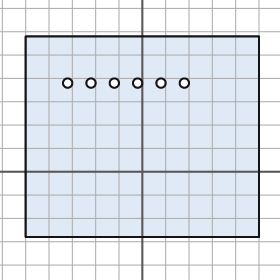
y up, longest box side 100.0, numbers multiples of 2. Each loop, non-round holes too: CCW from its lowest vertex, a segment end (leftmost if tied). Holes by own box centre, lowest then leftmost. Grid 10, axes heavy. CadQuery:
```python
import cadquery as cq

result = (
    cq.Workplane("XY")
    .moveTo(-50.0, -28.0)
    .lineTo(50.0, -28.0)
    .lineTo(50.0, 58.0)
    .lineTo(-50.0, 58.0)
    .close()
    .moveTo(-32.0, 38.0)
    .circle(2.0)
    .moveTo(-22.0, 38.0)
    .circle(2.0)
    .moveTo(-12.0, 38.0)
    .circle(2.0)
    .moveTo(-2.0, 38.0)
    .circle(2.0)
    .moveTo(8.0, 38.0)
    .circle(2.0)
    .moveTo(18.0, 38.0)
    .circle(2.0)
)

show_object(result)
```